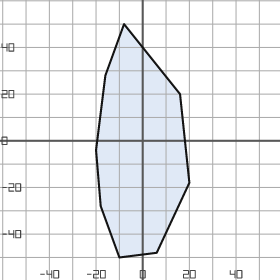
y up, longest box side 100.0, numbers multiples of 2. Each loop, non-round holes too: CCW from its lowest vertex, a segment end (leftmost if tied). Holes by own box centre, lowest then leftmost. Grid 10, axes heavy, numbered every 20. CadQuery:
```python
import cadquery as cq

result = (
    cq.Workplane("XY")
    .moveTo(-10.0, -50.0)
    .lineTo(6.0, -48.0)
    .lineTo(20.0, -18.0)
    .lineTo(16.0, 20.0)
    .lineTo(-8.0, 50.0)
    .lineTo(-16.0, 28.0)
    .lineTo(-20.0, -4.0)
    .lineTo(-18.0, -28.0)
    .close()
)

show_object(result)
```